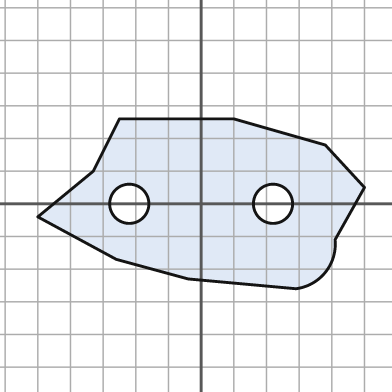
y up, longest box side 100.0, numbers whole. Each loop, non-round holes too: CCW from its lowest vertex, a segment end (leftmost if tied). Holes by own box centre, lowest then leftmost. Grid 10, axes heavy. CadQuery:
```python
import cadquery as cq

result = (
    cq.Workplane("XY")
    .moveTo(29.0, -26.0)
    .threePointArc((38.0, -21.0), (41.0, -11.0))
    .lineTo(50.0, 5.0)
    .lineTo(38.0, 18.0)
    .lineTo(10.0, 26.0)
    .lineTo(-25.0, 26.0)
    .lineTo(-33.0, 10.0)
    .lineTo(-50.0, -4.0)
    .lineTo(-26.0, -17.0)
    .lineTo(-4.0, -23.0)
    .close()
    .moveTo(-22.0, 0.0)
    .circle(6.0)
    .moveTo(22.0, 0.0)
    .circle(6.0)
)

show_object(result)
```